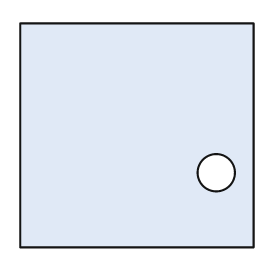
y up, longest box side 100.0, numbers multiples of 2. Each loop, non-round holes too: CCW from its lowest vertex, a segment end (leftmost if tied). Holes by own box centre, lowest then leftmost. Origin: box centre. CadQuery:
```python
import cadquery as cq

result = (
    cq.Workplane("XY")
    .moveTo(-50.0, -48.0)
    .lineTo(50.0, -48.0)
    .lineTo(50.0, 48.0)
    .lineTo(-50.0, 48.0)
    .close()
    .moveTo(34.0, -16.0)
    .circle(8.0)
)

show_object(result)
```